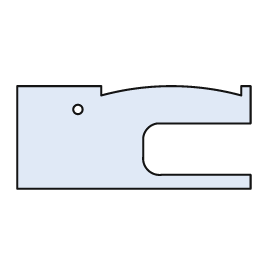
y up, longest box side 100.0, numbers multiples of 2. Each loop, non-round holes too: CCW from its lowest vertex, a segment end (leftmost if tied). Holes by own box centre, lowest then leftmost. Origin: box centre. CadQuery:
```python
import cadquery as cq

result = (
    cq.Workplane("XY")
    .moveTo(-50.0, -22.0)
    .lineTo(50.0, -22.0)
    .lineTo(50.0, -16.0)
    .lineTo(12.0, -16.0)
    .threePointArc((6.0, -14.0), (4.0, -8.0))
    .lineTo(4.0, 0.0)
    .threePointArc((6.0, 4.0), (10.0, 6.0))
    .lineTo(50.0, 6.0)
    .lineTo(50.0, 22.0)
    .lineTo(46.0, 22.0)
    .lineTo(46.0, 18.0)
    .threePointArc((16.0, 22.0), (-14.0, 18.0))
    .lineTo(-14.0, 22.0)
    .lineTo(-50.0, 22.0)
    .close()
    .moveTo(-24.0, 12.0)
    .circle(2.0)
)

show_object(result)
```